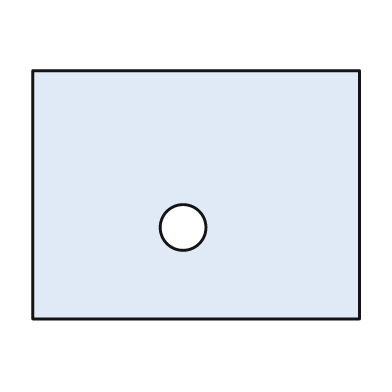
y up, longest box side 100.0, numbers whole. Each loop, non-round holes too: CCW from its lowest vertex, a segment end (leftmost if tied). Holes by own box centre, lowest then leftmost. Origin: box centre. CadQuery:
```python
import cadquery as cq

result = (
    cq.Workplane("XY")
    .moveTo(-50.0, -38.0)
    .lineTo(50.0, -38.0)
    .lineTo(50.0, 38.0)
    .lineTo(-50.0, 38.0)
    .close()
    .moveTo(-4.0, -10.0)
    .circle(7.0)
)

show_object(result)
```